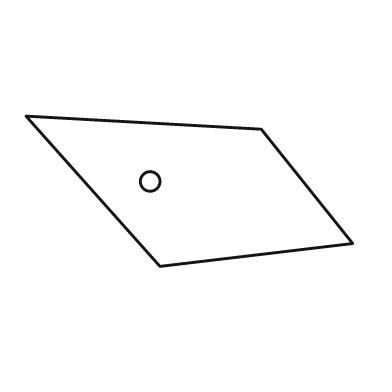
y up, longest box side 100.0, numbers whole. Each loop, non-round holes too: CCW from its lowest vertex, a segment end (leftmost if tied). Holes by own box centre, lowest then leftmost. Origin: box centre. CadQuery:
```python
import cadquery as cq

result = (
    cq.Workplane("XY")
    .moveTo(-9.0, -23.0)
    .lineTo(50.0, -16.0)
    .lineTo(22.0, 19.0)
    .lineTo(-50.0, 23.0)
    .close()
    .moveTo(-12.0, 3.0)
    .circle(3.0)
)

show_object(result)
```